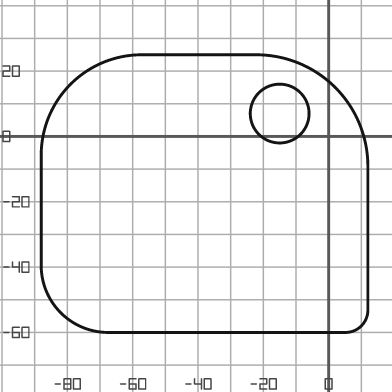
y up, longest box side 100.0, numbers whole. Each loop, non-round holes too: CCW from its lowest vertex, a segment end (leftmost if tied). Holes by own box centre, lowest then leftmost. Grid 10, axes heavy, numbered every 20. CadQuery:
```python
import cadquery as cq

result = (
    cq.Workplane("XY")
    .moveTo(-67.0, -60.0)
    .lineTo(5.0, -60.0)
    .threePointArc((10.0, -58.0), (12.0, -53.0))
    .lineTo(12.0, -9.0)
    .threePointArc((2.0, 15.0), (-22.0, 25.0))
    .lineTo(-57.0, 25.0)
    .threePointArc((-79.0, 16.0), (-88.0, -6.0))
    .lineTo(-88.0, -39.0)
    .threePointArc((-82.0, -54.0), (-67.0, -60.0))
    .close()
    .moveTo(-15.0, 7.0)
    .circle(9.0)
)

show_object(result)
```